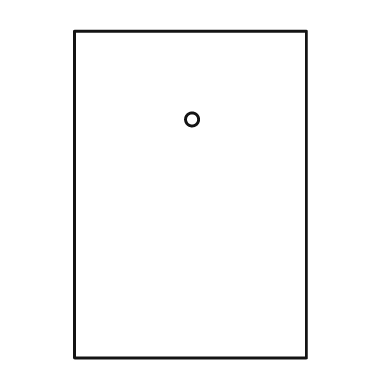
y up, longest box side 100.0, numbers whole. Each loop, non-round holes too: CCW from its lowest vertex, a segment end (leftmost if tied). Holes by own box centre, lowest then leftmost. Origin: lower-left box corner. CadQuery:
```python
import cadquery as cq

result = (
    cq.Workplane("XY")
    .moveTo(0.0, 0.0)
    .lineTo(71.0, 0.0)
    .lineTo(71.0, 100.0)
    .lineTo(0.0, 100.0)
    .close()
    .moveTo(36.0, 73.0)
    .circle(2.0)
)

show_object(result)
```